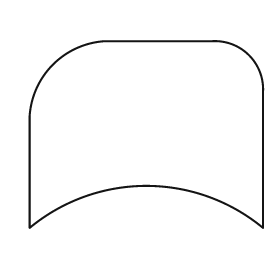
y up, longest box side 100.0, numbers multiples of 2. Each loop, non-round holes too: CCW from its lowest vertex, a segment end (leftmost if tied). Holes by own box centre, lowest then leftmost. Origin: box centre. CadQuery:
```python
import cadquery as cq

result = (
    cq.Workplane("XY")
    .moveTo(-50.0, -40.0)
    .threePointArc((0.0, -22.0), (50.0, -40.0))
    .lineTo(50.0, 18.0)
    .threePointArc((44.0, 34.0), (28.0, 40.0))
    .lineTo(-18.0, 40.0)
    .threePointArc((-40.0, 30.0), (-50.0, 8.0))
    .close()
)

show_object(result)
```